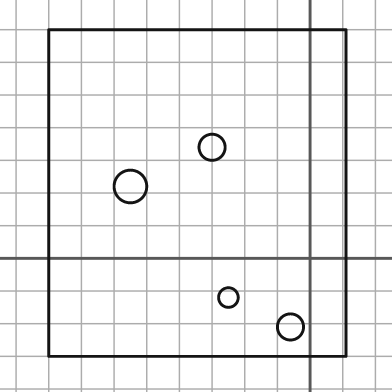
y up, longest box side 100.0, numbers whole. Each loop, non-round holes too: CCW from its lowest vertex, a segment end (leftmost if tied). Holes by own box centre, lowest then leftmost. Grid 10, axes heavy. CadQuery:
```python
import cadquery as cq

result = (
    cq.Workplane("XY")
    .moveTo(-80.0, -30.0)
    .lineTo(11.0, -30.0)
    .lineTo(11.0, 70.0)
    .lineTo(-80.0, 70.0)
    .close()
    .moveTo(-6.0, -21.0)
    .circle(4.0)
    .moveTo(-25.0, -12.0)
    .circle(3.0)
    .moveTo(-55.0, 22.0)
    .circle(5.0)
    .moveTo(-30.0, 34.0)
    .circle(4.0)
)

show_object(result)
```